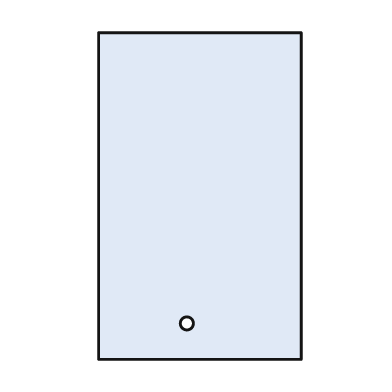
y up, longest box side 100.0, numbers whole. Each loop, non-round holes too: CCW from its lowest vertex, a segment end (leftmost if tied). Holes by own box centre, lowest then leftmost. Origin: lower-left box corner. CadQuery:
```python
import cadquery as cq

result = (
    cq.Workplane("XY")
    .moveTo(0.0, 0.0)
    .lineTo(62.0, 0.0)
    .lineTo(62.0, 100.0)
    .lineTo(0.0, 100.0)
    .close()
    .moveTo(27.0, 11.0)
    .circle(2.0)
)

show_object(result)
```